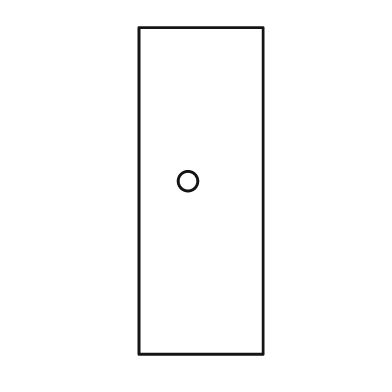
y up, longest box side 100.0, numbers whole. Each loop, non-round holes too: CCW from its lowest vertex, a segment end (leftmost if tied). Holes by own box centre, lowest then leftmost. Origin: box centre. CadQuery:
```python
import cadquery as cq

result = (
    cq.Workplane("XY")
    .moveTo(-19.0, -50.0)
    .lineTo(19.0, -50.0)
    .lineTo(19.0, 50.0)
    .lineTo(-19.0, 50.0)
    .close()
    .moveTo(-4.0, 3.0)
    .circle(3.0)
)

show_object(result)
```